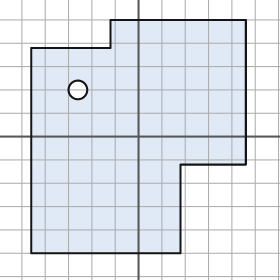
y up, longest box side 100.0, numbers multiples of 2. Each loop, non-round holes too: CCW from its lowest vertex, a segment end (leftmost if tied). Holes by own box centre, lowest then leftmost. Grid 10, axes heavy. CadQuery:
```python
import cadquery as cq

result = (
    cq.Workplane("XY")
    .moveTo(-46.0, -50.0)
    .lineTo(18.0, -50.0)
    .lineTo(18.0, -12.0)
    .lineTo(46.0, -12.0)
    .lineTo(46.0, 50.0)
    .lineTo(-12.0, 50.0)
    .lineTo(-12.0, 38.0)
    .lineTo(-46.0, 38.0)
    .close()
    .moveTo(-26.0, 20.0)
    .circle(4.0)
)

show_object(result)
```